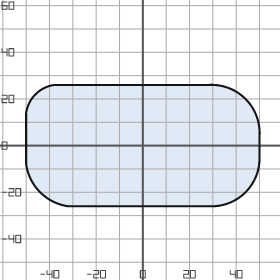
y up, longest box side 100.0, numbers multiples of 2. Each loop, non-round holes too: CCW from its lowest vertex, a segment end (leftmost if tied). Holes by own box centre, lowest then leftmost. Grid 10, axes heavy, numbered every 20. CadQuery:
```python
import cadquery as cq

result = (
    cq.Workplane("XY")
    .moveTo(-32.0, -26.0)
    .lineTo(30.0, -26.0)
    .threePointArc((44.0, -20.0), (50.0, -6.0))
    .lineTo(50.0, 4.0)
    .threePointArc((44.0, 20.0), (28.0, 26.0))
    .lineTo(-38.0, 26.0)
    .threePointArc((-46.0, 22.0), (-50.0, 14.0))
    .lineTo(-50.0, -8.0)
    .threePointArc((-44.0, -20.0), (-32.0, -26.0))
    .close()
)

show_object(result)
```